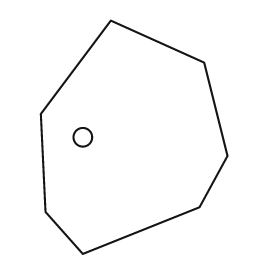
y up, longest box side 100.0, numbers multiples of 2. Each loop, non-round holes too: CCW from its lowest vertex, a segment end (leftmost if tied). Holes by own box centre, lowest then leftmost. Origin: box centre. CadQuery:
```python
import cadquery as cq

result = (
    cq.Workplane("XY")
    .moveTo(-22.0, -50.0)
    .lineTo(28.0, -30.0)
    .lineTo(40.0, -8.0)
    .lineTo(30.0, 32.0)
    .lineTo(-10.0, 50.0)
    .lineTo(-40.0, 10.0)
    .lineTo(-38.0, -32.0)
    .close()
    .moveTo(-22.0, 0.0)
    .circle(4.0)
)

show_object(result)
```